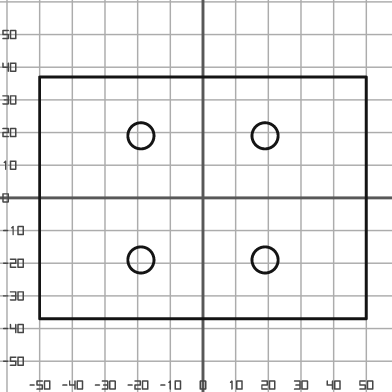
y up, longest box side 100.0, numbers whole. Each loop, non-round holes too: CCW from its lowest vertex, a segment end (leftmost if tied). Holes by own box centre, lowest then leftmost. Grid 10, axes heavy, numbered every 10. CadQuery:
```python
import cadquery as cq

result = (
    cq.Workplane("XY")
    .moveTo(-50.0, -37.0)
    .lineTo(50.0, -37.0)
    .lineTo(50.0, 37.0)
    .lineTo(-50.0, 37.0)
    .close()
    .moveTo(-19.0, -19.0)
    .circle(4.0)
    .moveTo(19.0, -19.0)
    .circle(4.0)
    .moveTo(-19.0, 19.0)
    .circle(4.0)
    .moveTo(19.0, 19.0)
    .circle(4.0)
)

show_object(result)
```